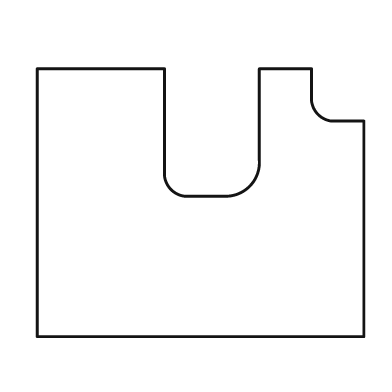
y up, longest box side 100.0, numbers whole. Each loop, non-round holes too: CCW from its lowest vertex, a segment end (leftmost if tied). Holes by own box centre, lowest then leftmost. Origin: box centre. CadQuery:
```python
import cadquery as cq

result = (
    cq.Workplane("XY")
    .moveTo(-50.0, -41.0)
    .lineTo(50.0, -41.0)
    .lineTo(50.0, 25.0)
    .lineTo(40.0, 25.0)
    .threePointArc((36.0, 27.0), (34.0, 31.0))
    .lineTo(34.0, 41.0)
    .lineTo(18.0, 41.0)
    .lineTo(18.0, 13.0)
    .threePointArc((15.0, 5.0), (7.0, 2.0))
    .lineTo(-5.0, 2.0)
    .threePointArc((-9.0, 4.0), (-11.0, 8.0))
    .lineTo(-11.0, 41.0)
    .lineTo(-50.0, 41.0)
    .close()
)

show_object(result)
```